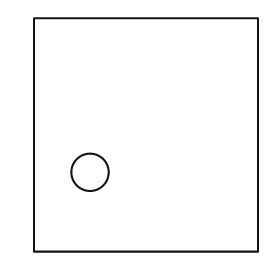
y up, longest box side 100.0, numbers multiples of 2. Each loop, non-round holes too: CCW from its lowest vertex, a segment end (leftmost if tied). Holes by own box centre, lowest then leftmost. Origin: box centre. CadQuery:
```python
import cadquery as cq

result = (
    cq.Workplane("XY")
    .moveTo(-48.0, -50.0)
    .lineTo(48.0, -50.0)
    .lineTo(48.0, 50.0)
    .lineTo(-48.0, 50.0)
    .close()
    .moveTo(-24.0, -16.0)
    .circle(8.0)
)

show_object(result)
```